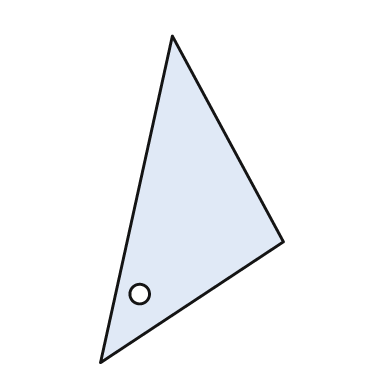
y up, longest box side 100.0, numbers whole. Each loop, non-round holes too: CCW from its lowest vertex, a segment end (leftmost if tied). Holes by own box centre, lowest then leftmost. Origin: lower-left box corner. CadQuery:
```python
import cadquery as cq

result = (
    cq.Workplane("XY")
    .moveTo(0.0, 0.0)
    .lineTo(56.0, 37.0)
    .lineTo(22.0, 100.0)
    .close()
    .moveTo(12.0, 21.0)
    .circle(3.0)
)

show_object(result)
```